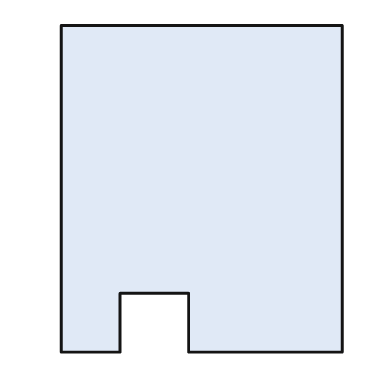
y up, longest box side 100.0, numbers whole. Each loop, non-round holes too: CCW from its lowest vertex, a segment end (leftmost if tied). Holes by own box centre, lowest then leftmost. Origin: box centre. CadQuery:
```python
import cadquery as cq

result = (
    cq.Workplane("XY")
    .moveTo(-43.0, -50.0)
    .lineTo(-25.0, -50.0)
    .lineTo(-25.0, -32.0)
    .lineTo(-4.0, -32.0)
    .lineTo(-4.0, -50.0)
    .lineTo(43.0, -50.0)
    .lineTo(43.0, 50.0)
    .lineTo(-43.0, 50.0)
    .close()
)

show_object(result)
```